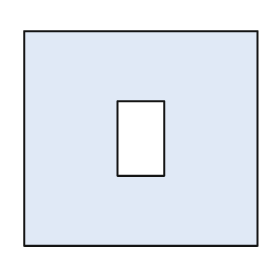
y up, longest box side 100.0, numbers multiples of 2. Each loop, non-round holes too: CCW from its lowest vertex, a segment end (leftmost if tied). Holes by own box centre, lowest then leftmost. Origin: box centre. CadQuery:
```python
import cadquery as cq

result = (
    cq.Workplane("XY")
    .moveTo(-50.0, -46.0)
    .lineTo(50.0, -46.0)
    .lineTo(50.0, 46.0)
    .lineTo(-50.0, 46.0)
    .close()
    .moveTo(-10.0, -16.0)
    .lineTo(10.0, -16.0)
    .lineTo(10.0, 16.0)
    .lineTo(-10.0, 16.0)
    .close()
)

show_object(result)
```